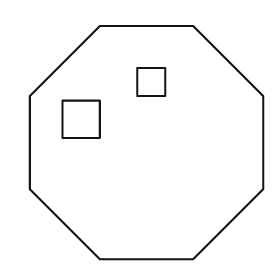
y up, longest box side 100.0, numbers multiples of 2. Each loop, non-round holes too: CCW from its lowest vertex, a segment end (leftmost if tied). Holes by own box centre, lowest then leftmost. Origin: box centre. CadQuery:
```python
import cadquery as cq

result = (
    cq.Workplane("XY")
    .moveTo(-20.0, -50.0)
    .lineTo(20.0, -50.0)
    .lineTo(50.0, -20.0)
    .lineTo(50.0, 20.0)
    .lineTo(20.0, 50.0)
    .lineTo(-20.0, 50.0)
    .lineTo(-50.0, 20.0)
    .lineTo(-50.0, -20.0)
    .close()
    .moveTo(-36.0, 2.0)
    .lineTo(-20.0, 2.0)
    .lineTo(-20.0, 18.0)
    .lineTo(-36.0, 18.0)
    .close()
    .moveTo(-4.0, 20.0)
    .lineTo(8.0, 20.0)
    .lineTo(8.0, 32.0)
    .lineTo(-4.0, 32.0)
    .close()
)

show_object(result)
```